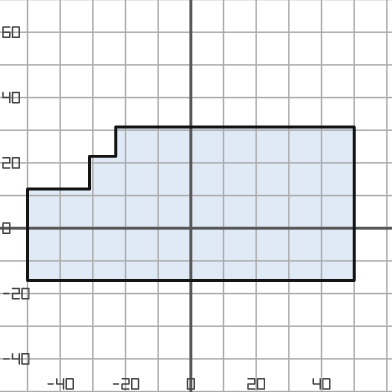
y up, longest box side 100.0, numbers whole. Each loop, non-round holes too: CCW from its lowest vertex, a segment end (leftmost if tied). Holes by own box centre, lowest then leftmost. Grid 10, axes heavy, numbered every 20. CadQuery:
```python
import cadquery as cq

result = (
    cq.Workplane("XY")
    .moveTo(-50.0, -16.0)
    .lineTo(50.0, -16.0)
    .lineTo(50.0, 31.0)
    .lineTo(-23.0, 31.0)
    .lineTo(-23.0, 22.0)
    .lineTo(-31.0, 22.0)
    .lineTo(-31.0, 12.0)
    .lineTo(-50.0, 12.0)
    .close()
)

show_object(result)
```